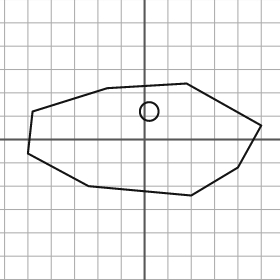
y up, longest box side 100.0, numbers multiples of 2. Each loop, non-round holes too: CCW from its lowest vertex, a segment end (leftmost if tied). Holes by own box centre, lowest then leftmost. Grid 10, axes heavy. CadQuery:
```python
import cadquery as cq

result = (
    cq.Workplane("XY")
    .moveTo(20.0, -24.0)
    .lineTo(40.0, -12.0)
    .lineTo(50.0, 6.0)
    .lineTo(18.0, 24.0)
    .lineTo(-16.0, 22.0)
    .lineTo(-48.0, 12.0)
    .lineTo(-50.0, -6.0)
    .lineTo(-24.0, -20.0)
    .close()
    .moveTo(2.0, 12.0)
    .circle(4.0)
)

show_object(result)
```